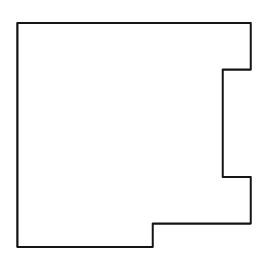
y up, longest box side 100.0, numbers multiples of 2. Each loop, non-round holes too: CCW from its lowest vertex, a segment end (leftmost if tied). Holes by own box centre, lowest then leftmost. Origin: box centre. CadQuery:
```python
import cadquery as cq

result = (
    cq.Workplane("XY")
    .moveTo(-50.0, -48.0)
    .lineTo(8.0, -48.0)
    .lineTo(8.0, -38.0)
    .lineTo(50.0, -38.0)
    .lineTo(50.0, -18.0)
    .lineTo(38.0, -18.0)
    .lineTo(38.0, 28.0)
    .lineTo(50.0, 28.0)
    .lineTo(50.0, 48.0)
    .lineTo(-50.0, 48.0)
    .close()
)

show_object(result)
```